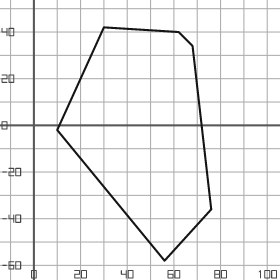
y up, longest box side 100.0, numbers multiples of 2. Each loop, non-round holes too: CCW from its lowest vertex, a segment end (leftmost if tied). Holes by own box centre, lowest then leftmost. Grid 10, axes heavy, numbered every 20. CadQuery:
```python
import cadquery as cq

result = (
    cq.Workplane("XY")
    .moveTo(56.0, -58.0)
    .lineTo(76.0, -36.0)
    .lineTo(68.0, 34.0)
    .lineTo(62.0, 40.0)
    .lineTo(30.0, 42.0)
    .lineTo(10.0, -2.0)
    .close()
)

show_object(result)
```